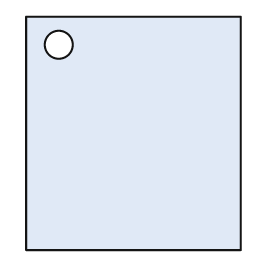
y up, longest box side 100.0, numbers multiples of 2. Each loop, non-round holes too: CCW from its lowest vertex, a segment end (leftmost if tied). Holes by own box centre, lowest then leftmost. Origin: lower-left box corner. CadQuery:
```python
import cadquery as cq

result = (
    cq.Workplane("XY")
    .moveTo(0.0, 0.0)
    .lineTo(92.0, 0.0)
    .lineTo(92.0, 100.0)
    .lineTo(0.0, 100.0)
    .close()
    .moveTo(14.0, 88.0)
    .circle(6.0)
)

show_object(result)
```